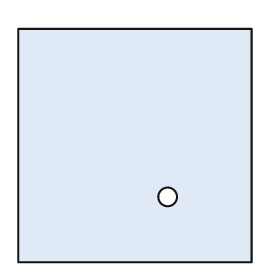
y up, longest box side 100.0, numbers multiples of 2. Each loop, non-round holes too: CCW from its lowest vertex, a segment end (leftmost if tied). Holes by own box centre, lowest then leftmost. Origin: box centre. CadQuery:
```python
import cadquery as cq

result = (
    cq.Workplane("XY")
    .moveTo(-50.0, -50.0)
    .lineTo(50.0, -50.0)
    .lineTo(50.0, 50.0)
    .lineTo(-50.0, 50.0)
    .close()
    .moveTo(14.0, -22.0)
    .circle(4.0)
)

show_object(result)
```